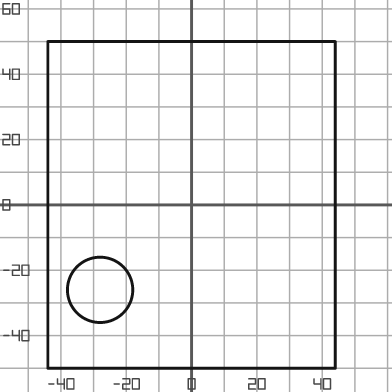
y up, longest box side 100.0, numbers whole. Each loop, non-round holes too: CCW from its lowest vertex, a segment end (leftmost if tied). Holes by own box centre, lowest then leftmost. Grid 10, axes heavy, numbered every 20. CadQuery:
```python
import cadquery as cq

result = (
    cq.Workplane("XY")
    .moveTo(-44.0, -50.0)
    .lineTo(44.0, -50.0)
    .lineTo(44.0, 50.0)
    .lineTo(-44.0, 50.0)
    .close()
    .moveTo(-28.0, -26.0)
    .circle(10.0)
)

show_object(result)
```